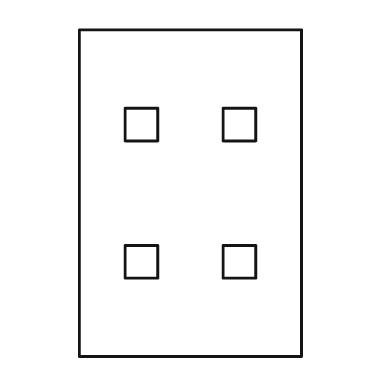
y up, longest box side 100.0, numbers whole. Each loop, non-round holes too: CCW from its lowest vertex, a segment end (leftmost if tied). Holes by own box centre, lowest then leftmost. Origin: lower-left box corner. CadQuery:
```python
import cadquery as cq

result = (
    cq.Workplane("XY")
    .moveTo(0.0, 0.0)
    .lineTo(68.0, 0.0)
    .lineTo(68.0, 100.0)
    .lineTo(0.0, 100.0)
    .close()
    .moveTo(14.0, 24.0)
    .lineTo(24.0, 24.0)
    .lineTo(24.0, 34.0)
    .lineTo(14.0, 34.0)
    .close()
    .moveTo(44.0, 24.0)
    .lineTo(54.0, 24.0)
    .lineTo(54.0, 34.0)
    .lineTo(44.0, 34.0)
    .close()
    .moveTo(14.0, 66.0)
    .lineTo(24.0, 66.0)
    .lineTo(24.0, 76.0)
    .lineTo(14.0, 76.0)
    .close()
    .moveTo(44.0, 66.0)
    .lineTo(54.0, 66.0)
    .lineTo(54.0, 76.0)
    .lineTo(44.0, 76.0)
    .close()
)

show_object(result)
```